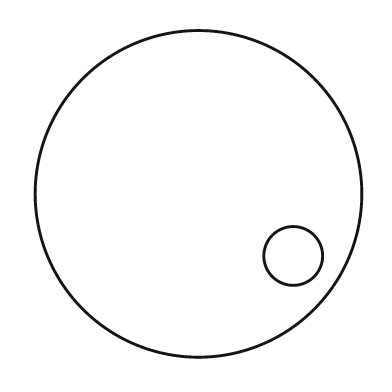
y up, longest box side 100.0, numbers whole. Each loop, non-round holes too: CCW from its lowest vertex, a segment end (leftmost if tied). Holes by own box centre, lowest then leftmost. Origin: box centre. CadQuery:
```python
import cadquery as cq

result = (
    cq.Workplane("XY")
    .moveTo(0.0, 0.0)
    .circle(50.0)
    .moveTo(29.0, -19.0)
    .circle(9.0)
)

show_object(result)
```